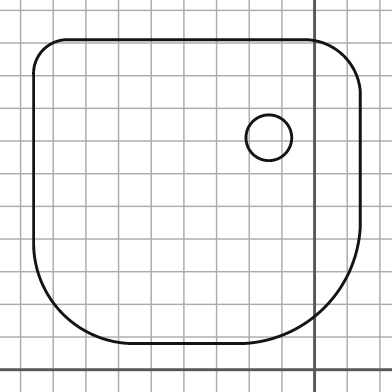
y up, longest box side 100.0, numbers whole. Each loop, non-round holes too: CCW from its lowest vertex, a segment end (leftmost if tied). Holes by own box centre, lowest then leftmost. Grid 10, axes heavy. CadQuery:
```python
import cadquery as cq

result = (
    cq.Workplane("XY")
    .moveTo(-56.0, 8.0)
    .lineTo(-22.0, 8.0)
    .threePointArc((3.0, 19.0), (14.0, 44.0))
    .lineTo(14.0, 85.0)
    .threePointArc((9.0, 96.0), (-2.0, 101.0))
    .lineTo(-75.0, 101.0)
    .threePointArc((-83.0, 98.0), (-86.0, 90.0))
    .lineTo(-86.0, 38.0)
    .threePointArc((-77.0, 17.0), (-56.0, 8.0))
    .close()
    .moveTo(-14.0, 71.0)
    .circle(7.0)
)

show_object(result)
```